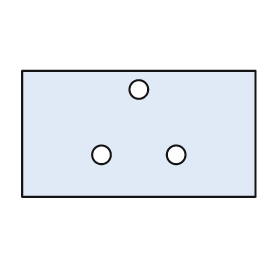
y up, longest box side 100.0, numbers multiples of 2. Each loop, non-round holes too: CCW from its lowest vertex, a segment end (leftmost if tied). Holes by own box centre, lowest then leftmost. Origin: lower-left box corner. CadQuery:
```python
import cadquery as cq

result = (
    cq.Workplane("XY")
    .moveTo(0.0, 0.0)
    .lineTo(100.0, 0.0)
    .lineTo(100.0, 54.0)
    .lineTo(0.0, 54.0)
    .close()
    .moveTo(34.0, 18.0)
    .circle(4.0)
    .moveTo(66.0, 18.0)
    .circle(4.0)
    .moveTo(50.0, 46.0)
    .circle(4.0)
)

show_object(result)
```